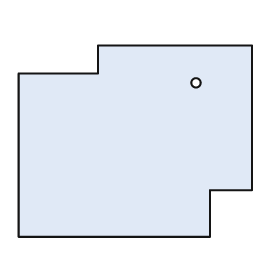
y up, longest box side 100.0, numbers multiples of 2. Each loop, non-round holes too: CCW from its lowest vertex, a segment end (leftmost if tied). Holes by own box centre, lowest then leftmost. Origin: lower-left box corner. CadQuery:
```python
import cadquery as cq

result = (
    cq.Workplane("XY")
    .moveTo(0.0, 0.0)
    .lineTo(82.0, 0.0)
    .lineTo(82.0, 20.0)
    .lineTo(100.0, 20.0)
    .lineTo(100.0, 82.0)
    .lineTo(34.0, 82.0)
    .lineTo(34.0, 70.0)
    .lineTo(0.0, 70.0)
    .close()
    .moveTo(76.0, 66.0)
    .circle(2.0)
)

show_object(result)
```